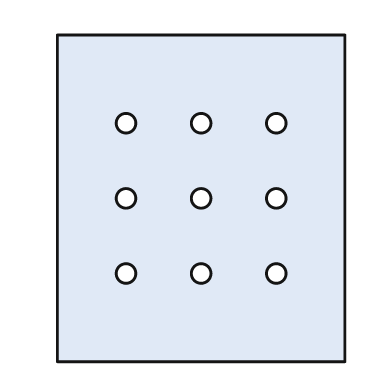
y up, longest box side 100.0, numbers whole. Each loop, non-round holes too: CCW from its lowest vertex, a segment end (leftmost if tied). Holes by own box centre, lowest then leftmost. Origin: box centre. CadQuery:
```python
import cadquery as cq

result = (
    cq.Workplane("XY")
    .moveTo(-44.0, -50.0)
    .lineTo(44.0, -50.0)
    .lineTo(44.0, 50.0)
    .lineTo(-44.0, 50.0)
    .close()
    .moveTo(-23.0, -23.0)
    .circle(3.0)
    .moveTo(0.0, -23.0)
    .circle(3.0)
    .moveTo(23.0, -23.0)
    .circle(3.0)
    .moveTo(-23.0, 0.0)
    .circle(3.0)
    .moveTo(0.0, 0.0)
    .circle(3.0)
    .moveTo(23.0, 0.0)
    .circle(3.0)
    .moveTo(-23.0, 23.0)
    .circle(3.0)
    .moveTo(0.0, 23.0)
    .circle(3.0)
    .moveTo(23.0, 23.0)
    .circle(3.0)
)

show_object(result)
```